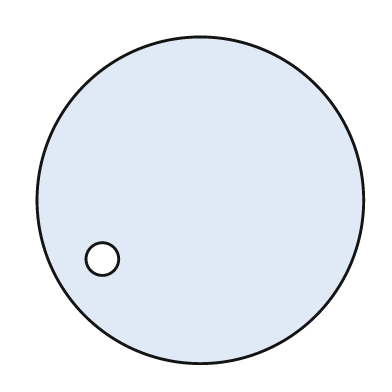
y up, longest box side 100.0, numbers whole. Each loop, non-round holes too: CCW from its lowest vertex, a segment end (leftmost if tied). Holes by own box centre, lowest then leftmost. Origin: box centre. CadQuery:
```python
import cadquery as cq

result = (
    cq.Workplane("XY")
    .moveTo(0.0, 0.0)
    .circle(50.0)
    .moveTo(-30.0, -18.0)
    .circle(5.0)
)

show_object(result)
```